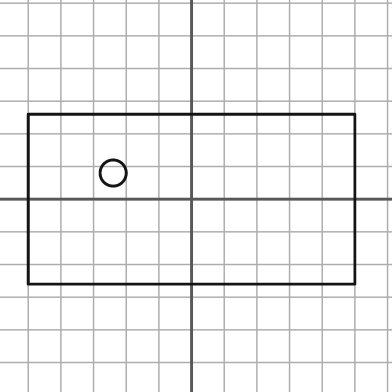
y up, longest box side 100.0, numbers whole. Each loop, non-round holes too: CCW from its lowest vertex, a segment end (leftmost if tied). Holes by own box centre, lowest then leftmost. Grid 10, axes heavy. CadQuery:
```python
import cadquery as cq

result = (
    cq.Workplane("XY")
    .moveTo(-50.0, -26.0)
    .lineTo(50.0, -26.0)
    .lineTo(50.0, 26.0)
    .lineTo(-50.0, 26.0)
    .close()
    .moveTo(-24.0, 8.0)
    .circle(4.0)
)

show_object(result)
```